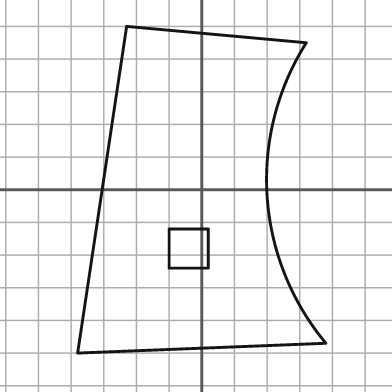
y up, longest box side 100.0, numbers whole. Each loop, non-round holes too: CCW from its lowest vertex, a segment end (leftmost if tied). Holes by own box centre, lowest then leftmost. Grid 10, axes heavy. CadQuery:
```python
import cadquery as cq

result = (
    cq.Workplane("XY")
    .moveTo(-38.0, -50.0)
    .lineTo(38.0, -47.0)
    .threePointArc((20.0, -2.0), (32.0, 45.0))
    .lineTo(-23.0, 50.0)
    .close()
    .moveTo(-10.0, -24.0)
    .lineTo(2.0, -24.0)
    .lineTo(2.0, -12.0)
    .lineTo(-10.0, -12.0)
    .close()
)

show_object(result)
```